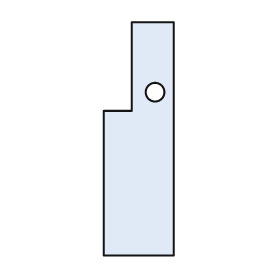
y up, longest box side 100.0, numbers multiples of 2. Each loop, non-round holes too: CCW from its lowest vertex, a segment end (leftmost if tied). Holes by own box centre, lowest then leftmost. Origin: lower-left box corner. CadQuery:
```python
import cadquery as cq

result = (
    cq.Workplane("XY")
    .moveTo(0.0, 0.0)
    .lineTo(30.0, 0.0)
    .lineTo(30.0, 100.0)
    .lineTo(12.0, 100.0)
    .lineTo(12.0, 62.0)
    .lineTo(0.0, 62.0)
    .close()
    .moveTo(22.0, 70.0)
    .circle(4.0)
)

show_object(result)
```